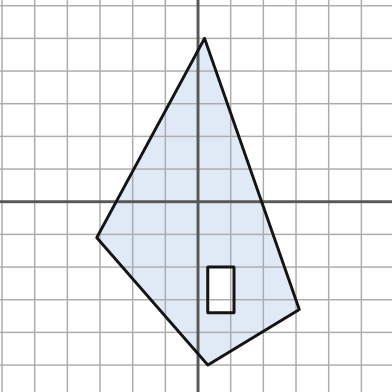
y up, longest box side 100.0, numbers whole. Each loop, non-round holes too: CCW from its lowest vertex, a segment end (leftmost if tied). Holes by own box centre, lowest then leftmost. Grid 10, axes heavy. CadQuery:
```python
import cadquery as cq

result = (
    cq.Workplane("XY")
    .moveTo(3.0, -50.0)
    .lineTo(31.0, -33.0)
    .lineTo(2.0, 50.0)
    .lineTo(-31.0, -11.0)
    .close()
    .moveTo(3.0, -34.0)
    .lineTo(11.0, -34.0)
    .lineTo(11.0, -20.0)
    .lineTo(3.0, -20.0)
    .close()
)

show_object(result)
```